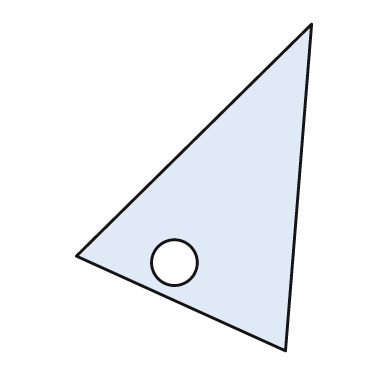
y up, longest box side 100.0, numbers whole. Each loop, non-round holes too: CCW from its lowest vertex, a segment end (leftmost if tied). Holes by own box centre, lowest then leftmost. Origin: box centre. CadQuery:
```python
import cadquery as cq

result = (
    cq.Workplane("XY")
    .moveTo(28.0, -50.0)
    .lineTo(36.0, 50.0)
    .lineTo(-36.0, -21.0)
    .close()
    .moveTo(-6.0, -23.0)
    .circle(7.0)
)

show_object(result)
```